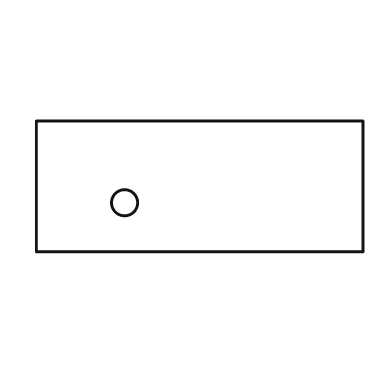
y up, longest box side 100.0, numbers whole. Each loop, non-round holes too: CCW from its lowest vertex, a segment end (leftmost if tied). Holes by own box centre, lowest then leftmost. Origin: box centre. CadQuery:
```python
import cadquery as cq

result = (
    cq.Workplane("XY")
    .moveTo(-50.0, -20.0)
    .lineTo(50.0, -20.0)
    .lineTo(50.0, 20.0)
    .lineTo(-50.0, 20.0)
    .close()
    .moveTo(-23.0, -5.0)
    .circle(4.0)
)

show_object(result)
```